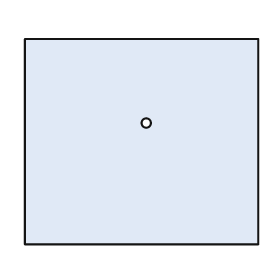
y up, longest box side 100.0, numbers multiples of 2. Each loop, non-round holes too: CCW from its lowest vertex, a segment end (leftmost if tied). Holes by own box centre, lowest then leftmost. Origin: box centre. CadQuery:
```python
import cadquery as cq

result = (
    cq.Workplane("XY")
    .moveTo(-50.0, -44.0)
    .lineTo(50.0, -44.0)
    .lineTo(50.0, 44.0)
    .lineTo(-50.0, 44.0)
    .close()
    .moveTo(2.0, 8.0)
    .circle(2.0)
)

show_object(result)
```